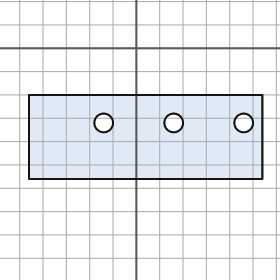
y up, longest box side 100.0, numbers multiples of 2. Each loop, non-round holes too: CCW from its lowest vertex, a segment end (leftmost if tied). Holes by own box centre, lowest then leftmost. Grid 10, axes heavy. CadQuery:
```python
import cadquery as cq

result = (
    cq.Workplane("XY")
    .moveTo(-46.0, -56.0)
    .lineTo(54.0, -56.0)
    .lineTo(54.0, -20.0)
    .lineTo(-46.0, -20.0)
    .close()
    .moveTo(-14.0, -32.0)
    .circle(4.0)
    .moveTo(16.0, -32.0)
    .circle(4.0)
    .moveTo(46.0, -32.0)
    .circle(4.0)
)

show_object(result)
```